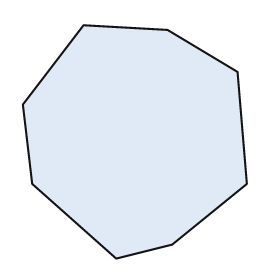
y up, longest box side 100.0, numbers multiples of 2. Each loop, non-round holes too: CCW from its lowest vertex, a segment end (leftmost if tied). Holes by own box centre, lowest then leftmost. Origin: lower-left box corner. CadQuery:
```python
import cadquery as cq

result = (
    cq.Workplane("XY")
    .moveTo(40.0, 0.0)
    .lineTo(64.0, 6.0)
    .lineTo(96.0, 32.0)
    .lineTo(92.0, 80.0)
    .lineTo(62.0, 98.0)
    .lineTo(26.0, 100.0)
    .lineTo(0.0, 66.0)
    .lineTo(4.0, 32.0)
    .close()
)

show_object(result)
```